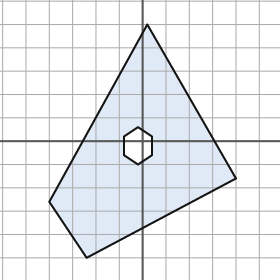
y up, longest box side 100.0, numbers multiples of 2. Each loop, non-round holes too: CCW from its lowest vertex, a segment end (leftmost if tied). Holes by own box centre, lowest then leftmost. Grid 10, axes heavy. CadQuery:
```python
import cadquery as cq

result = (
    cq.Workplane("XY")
    .moveTo(-24.0, -50.0)
    .lineTo(40.0, -16.0)
    .lineTo(2.0, 50.0)
    .lineTo(-40.0, -26.0)
    .close()
    .moveTo(-2.0, -10.0)
    .lineTo(4.0, -6.0)
    .lineTo(4.0, 2.0)
    .lineTo(-2.0, 6.0)
    .lineTo(-8.0, 2.0)
    .lineTo(-8.0, -6.0)
    .close()
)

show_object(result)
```